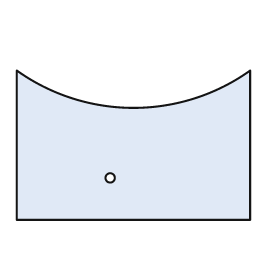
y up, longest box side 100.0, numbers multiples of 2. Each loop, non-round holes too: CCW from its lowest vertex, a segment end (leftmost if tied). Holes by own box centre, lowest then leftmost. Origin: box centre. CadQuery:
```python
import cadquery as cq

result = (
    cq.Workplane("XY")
    .moveTo(-50.0, -32.0)
    .lineTo(50.0, -32.0)
    .lineTo(50.0, 32.0)
    .threePointArc((0.0, 16.0), (-50.0, 32.0))
    .close()
    .moveTo(-10.0, -14.0)
    .circle(2.0)
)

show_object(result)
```